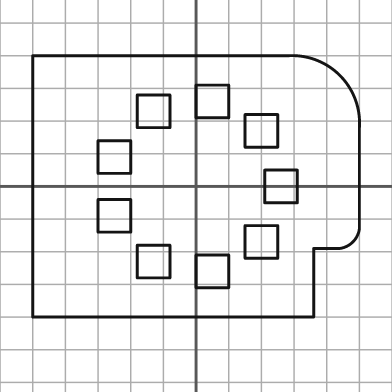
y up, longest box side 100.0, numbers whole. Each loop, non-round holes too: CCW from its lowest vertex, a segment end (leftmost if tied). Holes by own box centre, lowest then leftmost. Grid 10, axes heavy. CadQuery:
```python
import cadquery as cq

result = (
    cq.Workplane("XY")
    .moveTo(-50.0, -40.0)
    .lineTo(36.0, -40.0)
    .lineTo(36.0, -19.0)
    .lineTo(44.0, -19.0)
    .threePointArc((48.0, -17.0), (50.0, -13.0))
    .lineTo(50.0, 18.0)
    .threePointArc((44.0, 34.0), (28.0, 40.0))
    .lineTo(-50.0, 40.0)
    .close()
    .moveTo(0.0, -31.0)
    .lineTo(10.0, -31.0)
    .lineTo(10.0, -21.0)
    .lineTo(0.0, -21.0)
    .close()
    .moveTo(-18.0, -28.0)
    .lineTo(-8.0, -28.0)
    .lineTo(-8.0, -18.0)
    .lineTo(-18.0, -18.0)
    .close()
    .moveTo(15.0, -22.0)
    .lineTo(25.0, -22.0)
    .lineTo(25.0, -12.0)
    .lineTo(15.0, -12.0)
    .close()
    .moveTo(-30.0, -14.0)
    .lineTo(-20.0, -14.0)
    .lineTo(-20.0, -4.0)
    .lineTo(-30.0, -4.0)
    .close()
    .moveTo(21.0, -5.0)
    .lineTo(31.0, -5.0)
    .lineTo(31.0, 5.0)
    .lineTo(21.0, 5.0)
    .close()
    .moveTo(-30.0, 4.0)
    .lineTo(-20.0, 4.0)
    .lineTo(-20.0, 14.0)
    .lineTo(-30.0, 14.0)
    .close()
    .moveTo(15.0, 12.0)
    .lineTo(25.0, 12.0)
    .lineTo(25.0, 22.0)
    .lineTo(15.0, 22.0)
    .close()
    .moveTo(-18.0, 18.0)
    .lineTo(-8.0, 18.0)
    .lineTo(-8.0, 28.0)
    .lineTo(-18.0, 28.0)
    .close()
    .moveTo(0.0, 21.0)
    .lineTo(10.0, 21.0)
    .lineTo(10.0, 31.0)
    .lineTo(0.0, 31.0)
    .close()
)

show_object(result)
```